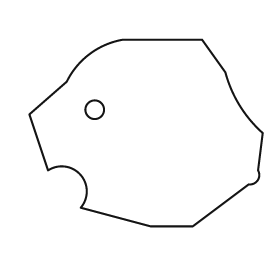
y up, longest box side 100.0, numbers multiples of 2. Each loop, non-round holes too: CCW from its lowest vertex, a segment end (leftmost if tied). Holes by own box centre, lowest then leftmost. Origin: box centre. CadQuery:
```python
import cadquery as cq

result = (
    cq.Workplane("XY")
    .moveTo(2.0, -40.0)
    .lineTo(20.0, -40.0)
    .lineTo(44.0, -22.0)
    .threePointArc((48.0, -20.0), (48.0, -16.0))
    .lineTo(50.0, 0.0)
    .threePointArc((40.0, 12.0), (34.0, 26.0))
    .lineTo(24.0, 40.0)
    .lineTo(-10.0, 40.0)
    .threePointArc((-24.0, 34.0), (-34.0, 22.0))
    .lineTo(-50.0, 8.0)
    .lineTo(-42.0, -16.0)
    .threePointArc((-28.0, -18.0), (-28.0, -32.0))
    .close()
    .moveTo(-22.0, 10.0)
    .circle(4.0)
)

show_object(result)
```